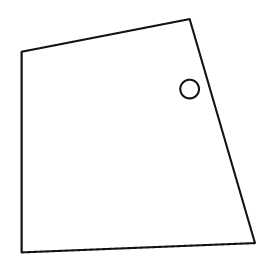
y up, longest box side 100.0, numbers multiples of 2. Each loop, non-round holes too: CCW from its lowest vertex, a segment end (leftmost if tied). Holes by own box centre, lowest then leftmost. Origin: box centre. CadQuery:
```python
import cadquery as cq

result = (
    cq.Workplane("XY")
    .moveTo(-50.0, -50.0)
    .lineTo(50.0, -46.0)
    .lineTo(22.0, 50.0)
    .lineTo(-50.0, 36.0)
    .close()
    .moveTo(22.0, 20.0)
    .circle(4.0)
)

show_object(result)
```